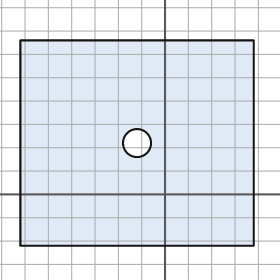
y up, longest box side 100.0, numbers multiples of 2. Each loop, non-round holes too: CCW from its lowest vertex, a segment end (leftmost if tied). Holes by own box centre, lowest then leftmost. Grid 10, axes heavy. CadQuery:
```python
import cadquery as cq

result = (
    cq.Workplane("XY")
    .moveTo(-62.0, -22.0)
    .lineTo(38.0, -22.0)
    .lineTo(38.0, 66.0)
    .lineTo(-62.0, 66.0)
    .close()
    .moveTo(-12.0, 22.0)
    .circle(6.0)
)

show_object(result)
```